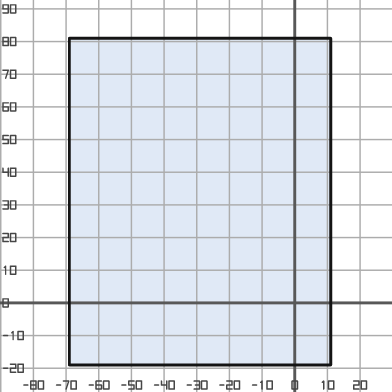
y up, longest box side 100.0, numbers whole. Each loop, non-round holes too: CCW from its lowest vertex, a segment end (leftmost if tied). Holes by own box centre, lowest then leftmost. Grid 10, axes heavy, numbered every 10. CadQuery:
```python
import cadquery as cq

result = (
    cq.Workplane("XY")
    .moveTo(-69.0, -19.0)
    .lineTo(11.0, -19.0)
    .lineTo(11.0, 81.0)
    .lineTo(-69.0, 81.0)
    .close()
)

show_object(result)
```